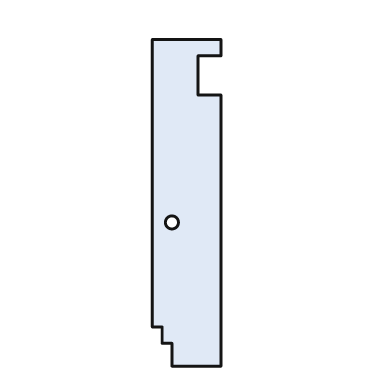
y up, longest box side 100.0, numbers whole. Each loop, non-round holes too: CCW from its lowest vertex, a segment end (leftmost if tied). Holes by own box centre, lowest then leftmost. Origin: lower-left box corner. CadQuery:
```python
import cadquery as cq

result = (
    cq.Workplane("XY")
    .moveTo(6.0, 0.0)
    .lineTo(21.0, 0.0)
    .lineTo(21.0, 83.0)
    .lineTo(14.0, 83.0)
    .lineTo(14.0, 95.0)
    .lineTo(21.0, 95.0)
    .lineTo(21.0, 100.0)
    .lineTo(0.0, 100.0)
    .lineTo(0.0, 12.0)
    .lineTo(3.0, 12.0)
    .lineTo(3.0, 7.0)
    .lineTo(6.0, 7.0)
    .close()
    .moveTo(6.0, 44.0)
    .circle(2.0)
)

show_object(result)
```